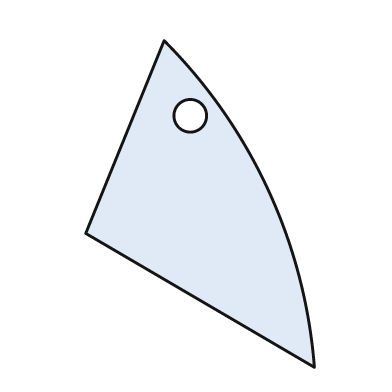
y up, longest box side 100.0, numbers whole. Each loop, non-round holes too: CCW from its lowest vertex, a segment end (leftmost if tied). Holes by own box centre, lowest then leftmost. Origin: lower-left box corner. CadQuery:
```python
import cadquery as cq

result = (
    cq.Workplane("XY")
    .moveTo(70.0, 0.0)
    .threePointArc((56.0, 54.0), (24.0, 100.0))
    .lineTo(0.0, 41.0)
    .close()
    .moveTo(32.0, 77.0)
    .circle(5.0)
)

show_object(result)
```